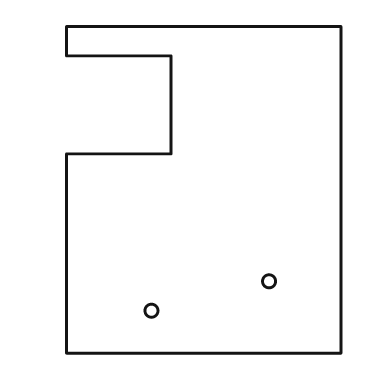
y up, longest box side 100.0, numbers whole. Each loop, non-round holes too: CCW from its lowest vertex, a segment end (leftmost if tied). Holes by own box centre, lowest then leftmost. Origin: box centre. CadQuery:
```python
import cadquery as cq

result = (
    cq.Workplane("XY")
    .moveTo(-42.0, -50.0)
    .lineTo(42.0, -50.0)
    .lineTo(42.0, 50.0)
    .lineTo(-42.0, 50.0)
    .lineTo(-42.0, 41.0)
    .lineTo(-10.0, 41.0)
    .lineTo(-10.0, 11.0)
    .lineTo(-42.0, 11.0)
    .close()
    .moveTo(-16.0, -37.0)
    .circle(2.0)
    .moveTo(20.0, -28.0)
    .circle(2.0)
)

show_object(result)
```